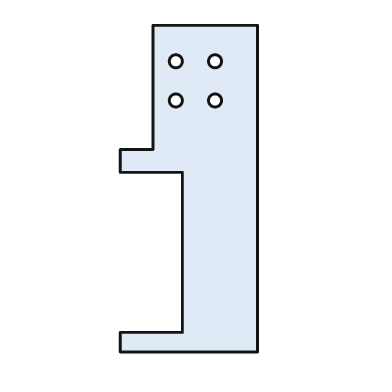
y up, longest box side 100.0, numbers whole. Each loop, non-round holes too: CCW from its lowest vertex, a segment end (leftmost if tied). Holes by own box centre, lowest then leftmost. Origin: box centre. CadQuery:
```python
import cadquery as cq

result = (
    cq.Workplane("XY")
    .moveTo(-21.0, -50.0)
    .lineTo(21.0, -50.0)
    .lineTo(21.0, 50.0)
    .lineTo(-11.0, 50.0)
    .lineTo(-11.0, 12.0)
    .lineTo(-21.0, 12.0)
    .lineTo(-21.0, 5.0)
    .lineTo(-2.0, 5.0)
    .lineTo(-2.0, -44.0)
    .lineTo(-21.0, -44.0)
    .close()
    .moveTo(-4.0, 27.0)
    .circle(2.0)
    .moveTo(8.0, 27.0)
    .circle(2.0)
    .moveTo(-4.0, 39.0)
    .circle(2.0)
    .moveTo(8.0, 39.0)
    .circle(2.0)
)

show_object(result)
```